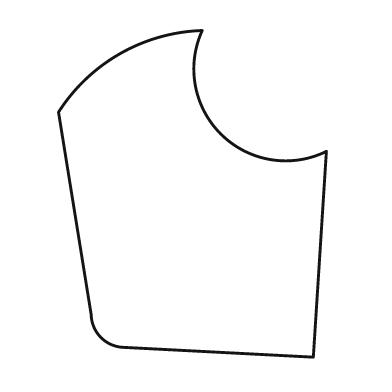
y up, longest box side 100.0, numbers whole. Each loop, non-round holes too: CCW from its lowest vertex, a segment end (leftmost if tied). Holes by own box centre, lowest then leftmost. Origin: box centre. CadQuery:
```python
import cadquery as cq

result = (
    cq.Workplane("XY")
    .moveTo(37.0, -50.0)
    .lineTo(41.0, 13.0)
    .threePointArc((9.0, 18.0), (3.0, 50.0))
    .threePointArc((-22.0, 43.0), (-41.0, 25.0))
    .lineTo(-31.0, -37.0)
    .threePointArc((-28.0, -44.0), (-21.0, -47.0))
    .close()
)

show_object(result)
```